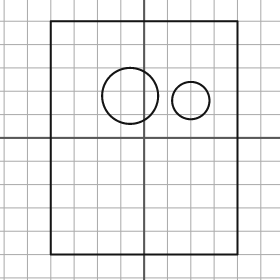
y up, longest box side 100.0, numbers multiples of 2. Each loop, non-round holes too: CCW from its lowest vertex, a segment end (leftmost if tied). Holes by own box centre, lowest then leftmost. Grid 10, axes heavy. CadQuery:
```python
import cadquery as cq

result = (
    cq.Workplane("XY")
    .moveTo(-40.0, -50.0)
    .lineTo(40.0, -50.0)
    .lineTo(40.0, 50.0)
    .lineTo(-40.0, 50.0)
    .close()
    .moveTo(20.0, 16.0)
    .circle(8.0)
    .moveTo(-6.0, 18.0)
    .circle(12.0)
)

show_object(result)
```